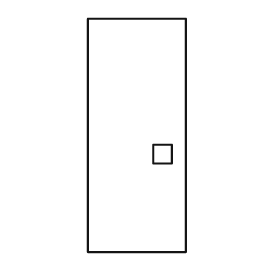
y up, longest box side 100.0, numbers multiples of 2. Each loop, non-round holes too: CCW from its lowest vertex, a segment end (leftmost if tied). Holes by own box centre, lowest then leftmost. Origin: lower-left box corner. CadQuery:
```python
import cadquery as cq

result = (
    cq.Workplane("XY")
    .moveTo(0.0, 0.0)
    .lineTo(42.0, 0.0)
    .lineTo(42.0, 100.0)
    .lineTo(0.0, 100.0)
    .close()
    .moveTo(28.0, 38.0)
    .lineTo(36.0, 38.0)
    .lineTo(36.0, 46.0)
    .lineTo(28.0, 46.0)
    .close()
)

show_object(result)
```